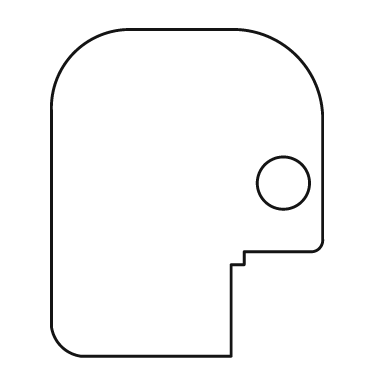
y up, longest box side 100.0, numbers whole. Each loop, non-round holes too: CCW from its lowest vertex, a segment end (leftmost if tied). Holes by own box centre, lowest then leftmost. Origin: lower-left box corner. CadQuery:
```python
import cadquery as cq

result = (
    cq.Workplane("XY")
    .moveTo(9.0, 0.0)
    .lineTo(55.0, 0.0)
    .lineTo(55.0, 28.0)
    .lineTo(59.0, 28.0)
    .lineTo(59.0, 32.0)
    .lineTo(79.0, 32.0)
    .threePointArc((82.0, 33.0), (83.0, 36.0))
    .lineTo(83.0, 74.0)
    .threePointArc((75.0, 92.0), (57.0, 100.0))
    .lineTo(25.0, 100.0)
    .threePointArc((7.0, 93.0), (0.0, 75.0))
    .lineTo(0.0, 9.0)
    .threePointArc((3.0, 3.0), (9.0, 0.0))
    .close()
    .moveTo(71.0, 53.0)
    .circle(8.0)
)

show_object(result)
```